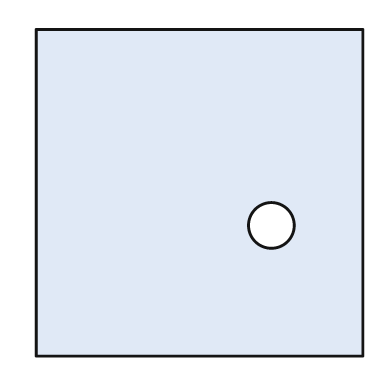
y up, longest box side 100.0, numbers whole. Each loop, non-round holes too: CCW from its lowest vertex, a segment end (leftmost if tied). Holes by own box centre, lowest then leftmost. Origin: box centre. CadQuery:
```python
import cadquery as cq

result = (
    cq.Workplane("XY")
    .moveTo(-50.0, -50.0)
    .lineTo(50.0, -50.0)
    .lineTo(50.0, 50.0)
    .lineTo(-50.0, 50.0)
    .close()
    .moveTo(22.0, -10.0)
    .circle(7.0)
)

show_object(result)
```